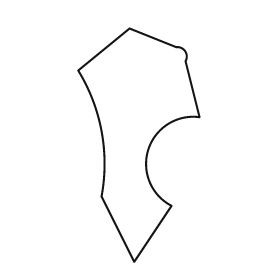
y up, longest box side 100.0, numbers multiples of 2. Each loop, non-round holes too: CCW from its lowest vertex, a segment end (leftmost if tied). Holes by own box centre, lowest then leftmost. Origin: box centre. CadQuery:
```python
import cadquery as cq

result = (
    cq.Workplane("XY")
    .moveTo(-2.0, -50.0)
    .lineTo(14.0, -26.0)
    .threePointArc((4.0, -2.0), (26.0, 12.0))
    .lineTo(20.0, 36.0)
    .threePointArc((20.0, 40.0), (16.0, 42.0))
    .lineTo(-4.0, 50.0)
    .lineTo(-26.0, 32.0)
    .threePointArc((-16.0, 6.0), (-16.0, -22.0))
    .close()
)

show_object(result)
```